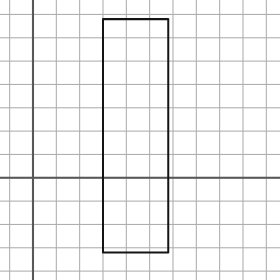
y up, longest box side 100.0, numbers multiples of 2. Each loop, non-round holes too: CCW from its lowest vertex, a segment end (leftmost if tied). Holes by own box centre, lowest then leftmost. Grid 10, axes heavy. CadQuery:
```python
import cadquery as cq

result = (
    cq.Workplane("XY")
    .moveTo(30.0, -32.0)
    .lineTo(58.0, -32.0)
    .lineTo(58.0, 68.0)
    .lineTo(30.0, 68.0)
    .close()
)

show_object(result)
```